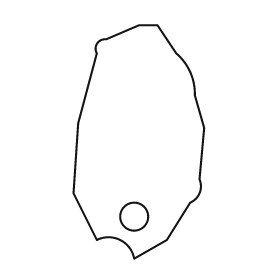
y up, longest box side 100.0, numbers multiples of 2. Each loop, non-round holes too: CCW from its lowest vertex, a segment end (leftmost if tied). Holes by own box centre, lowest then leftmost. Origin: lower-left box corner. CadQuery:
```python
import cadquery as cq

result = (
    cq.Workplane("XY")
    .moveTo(26.0, 0.0)
    .lineTo(40.0, 8.0)
    .lineTo(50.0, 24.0)
    .threePointArc((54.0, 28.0), (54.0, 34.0))
    .lineTo(56.0, 56.0)
    .lineTo(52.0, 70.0)
    .threePointArc((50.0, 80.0), (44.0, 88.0))
    .lineTo(36.0, 100.0)
    .lineTo(28.0, 100.0)
    .lineTo(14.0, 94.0)
    .threePointArc((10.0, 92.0), (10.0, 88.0))
    .lineTo(2.0, 58.0)
    .lineTo(0.0, 28.0)
    .lineTo(10.0, 8.0)
    .threePointArc((20.0, 8.0), (26.0, 0.0))
    .close()
    .moveTo(26.0, 18.0)
    .circle(6.0)
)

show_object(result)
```